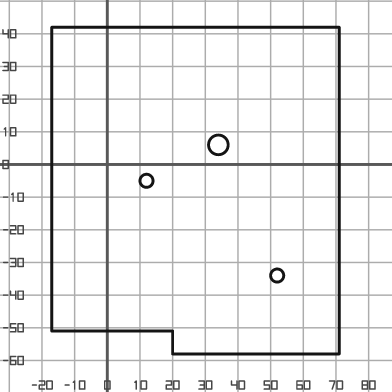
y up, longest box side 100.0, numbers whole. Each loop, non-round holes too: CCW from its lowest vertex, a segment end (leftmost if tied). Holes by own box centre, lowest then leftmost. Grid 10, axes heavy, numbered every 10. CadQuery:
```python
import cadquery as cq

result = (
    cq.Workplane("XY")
    .moveTo(20.0, -58.0)
    .lineTo(71.0, -58.0)
    .lineTo(71.0, 42.0)
    .lineTo(-17.0, 42.0)
    .lineTo(-17.0, -51.0)
    .lineTo(20.0, -51.0)
    .close()
    .moveTo(52.0, -34.0)
    .circle(2.0)
    .moveTo(12.0, -5.0)
    .circle(2.0)
    .moveTo(34.0, 6.0)
    .circle(3.0)
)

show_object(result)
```